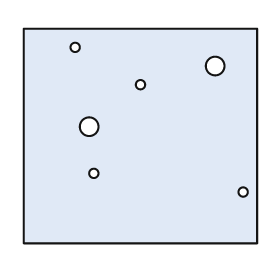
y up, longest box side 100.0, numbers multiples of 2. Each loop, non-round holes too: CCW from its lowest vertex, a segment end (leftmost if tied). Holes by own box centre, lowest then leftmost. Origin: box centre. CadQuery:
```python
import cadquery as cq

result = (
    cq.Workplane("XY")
    .moveTo(-50.0, -46.0)
    .lineTo(50.0, -46.0)
    .lineTo(50.0, 46.0)
    .lineTo(-50.0, 46.0)
    .close()
    .moveTo(44.0, -24.0)
    .circle(2.0)
    .moveTo(-20.0, -16.0)
    .circle(2.0)
    .moveTo(-22.0, 4.0)
    .circle(4.0)
    .moveTo(0.0, 22.0)
    .circle(2.0)
    .moveTo(32.0, 30.0)
    .circle(4.0)
    .moveTo(-28.0, 38.0)
    .circle(2.0)
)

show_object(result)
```